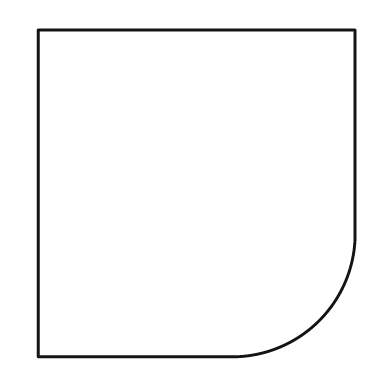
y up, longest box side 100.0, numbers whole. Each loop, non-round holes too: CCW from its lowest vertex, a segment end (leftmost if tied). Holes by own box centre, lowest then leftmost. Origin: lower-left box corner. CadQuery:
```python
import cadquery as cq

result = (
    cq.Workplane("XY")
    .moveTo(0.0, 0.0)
    .lineTo(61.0, 0.0)
    .threePointArc((86.0, 11.0), (97.0, 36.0))
    .lineTo(97.0, 100.0)
    .lineTo(0.0, 100.0)
    .close()
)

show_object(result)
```